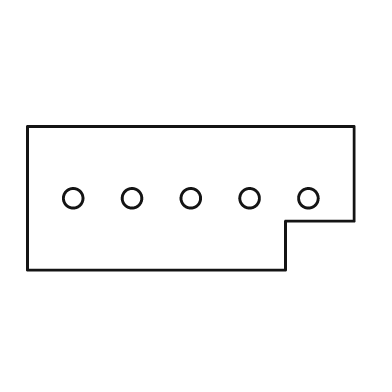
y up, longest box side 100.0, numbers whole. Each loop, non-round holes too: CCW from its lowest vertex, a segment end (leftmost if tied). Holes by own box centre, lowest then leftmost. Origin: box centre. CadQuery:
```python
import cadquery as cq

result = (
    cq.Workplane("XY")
    .moveTo(-50.0, -22.0)
    .lineTo(29.0, -22.0)
    .lineTo(29.0, -7.0)
    .lineTo(50.0, -7.0)
    .lineTo(50.0, 22.0)
    .lineTo(-50.0, 22.0)
    .close()
    .moveTo(-36.0, 0.0)
    .circle(3.0)
    .moveTo(-18.0, 0.0)
    .circle(3.0)
    .moveTo(0.0, 0.0)
    .circle(3.0)
    .moveTo(18.0, 0.0)
    .circle(3.0)
    .moveTo(36.0, 0.0)
    .circle(3.0)
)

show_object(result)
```